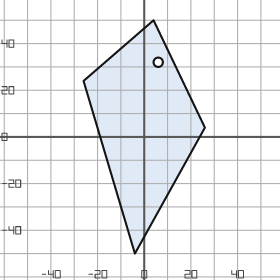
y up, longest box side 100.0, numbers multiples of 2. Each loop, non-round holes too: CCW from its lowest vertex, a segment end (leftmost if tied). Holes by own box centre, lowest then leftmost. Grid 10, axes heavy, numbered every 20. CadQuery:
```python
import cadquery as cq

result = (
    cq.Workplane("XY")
    .moveTo(-4.0, -50.0)
    .lineTo(26.0, 4.0)
    .lineTo(4.0, 50.0)
    .lineTo(-26.0, 24.0)
    .close()
    .moveTo(6.0, 32.0)
    .circle(2.0)
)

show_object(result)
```